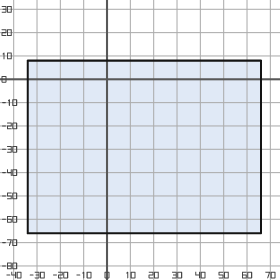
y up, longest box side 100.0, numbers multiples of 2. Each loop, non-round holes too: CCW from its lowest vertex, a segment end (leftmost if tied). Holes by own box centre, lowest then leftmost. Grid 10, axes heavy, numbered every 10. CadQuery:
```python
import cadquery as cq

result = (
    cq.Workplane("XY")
    .moveTo(-34.0, -66.0)
    .lineTo(66.0, -66.0)
    .lineTo(66.0, 8.0)
    .lineTo(-34.0, 8.0)
    .close()
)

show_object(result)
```